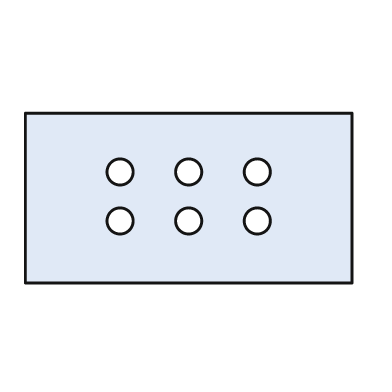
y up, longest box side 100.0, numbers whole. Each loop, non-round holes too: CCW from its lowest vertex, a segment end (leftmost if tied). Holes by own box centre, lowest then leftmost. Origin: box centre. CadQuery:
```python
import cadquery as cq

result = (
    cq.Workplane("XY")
    .moveTo(-50.0, -26.0)
    .lineTo(50.0, -26.0)
    .lineTo(50.0, 26.0)
    .lineTo(-50.0, 26.0)
    .close()
    .moveTo(-21.0, -7.0)
    .circle(4.0)
    .moveTo(0.0, -7.0)
    .circle(4.0)
    .moveTo(21.0, -7.0)
    .circle(4.0)
    .moveTo(-21.0, 8.0)
    .circle(4.0)
    .moveTo(0.0, 8.0)
    .circle(4.0)
    .moveTo(21.0, 8.0)
    .circle(4.0)
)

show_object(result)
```